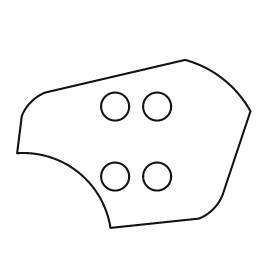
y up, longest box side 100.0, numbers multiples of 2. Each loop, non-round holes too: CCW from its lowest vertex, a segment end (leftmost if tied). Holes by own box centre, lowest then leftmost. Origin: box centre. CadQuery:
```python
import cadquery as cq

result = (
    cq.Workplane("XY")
    .moveTo(-10.0, -36.0)
    .lineTo(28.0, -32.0)
    .threePointArc((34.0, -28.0), (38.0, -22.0))
    .lineTo(50.0, 14.0)
    .threePointArc((38.0, 28.0), (22.0, 36.0))
    .lineTo(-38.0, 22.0)
    .threePointArc((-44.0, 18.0), (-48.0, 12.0))
    .lineTo(-50.0, -4.0)
    .threePointArc((-24.0, -12.0), (-10.0, -36.0))
    .close()
    .moveTo(-8.0, -14.0)
    .circle(6.0)
    .moveTo(10.0, -14.0)
    .circle(6.0)
    .moveTo(-8.0, 16.0)
    .circle(6.0)
    .moveTo(10.0, 16.0)
    .circle(6.0)
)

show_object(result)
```